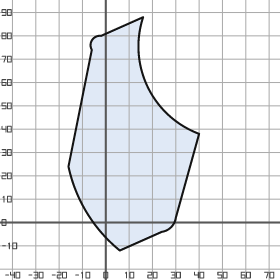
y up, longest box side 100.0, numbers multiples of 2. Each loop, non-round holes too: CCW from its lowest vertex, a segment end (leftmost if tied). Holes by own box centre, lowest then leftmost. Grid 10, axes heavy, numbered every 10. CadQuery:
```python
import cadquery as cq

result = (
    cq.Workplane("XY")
    .moveTo(6.0, -12.0)
    .lineTo(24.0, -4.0)
    .threePointArc((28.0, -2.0), (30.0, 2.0))
    .lineTo(40.0, 38.0)
    .threePointArc((18.0, 58.0), (16.0, 88.0))
    .lineTo(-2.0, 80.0)
    .threePointArc((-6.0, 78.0), (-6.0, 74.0))
    .lineTo(-16.0, 24.0)
    .threePointArc((-8.0, 4.0), (6.0, -12.0))
    .close()
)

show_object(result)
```